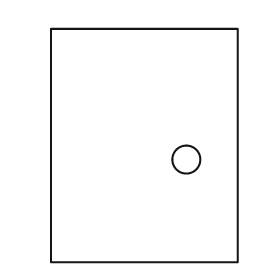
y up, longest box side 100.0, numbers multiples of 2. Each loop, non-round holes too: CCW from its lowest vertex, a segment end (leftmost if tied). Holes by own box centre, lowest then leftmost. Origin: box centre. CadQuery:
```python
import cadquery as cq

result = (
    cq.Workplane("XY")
    .moveTo(-40.0, -50.0)
    .lineTo(40.0, -50.0)
    .lineTo(40.0, 50.0)
    .lineTo(-40.0, 50.0)
    .close()
    .moveTo(18.0, -6.0)
    .circle(6.0)
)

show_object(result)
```